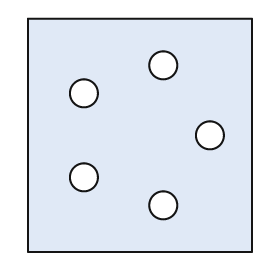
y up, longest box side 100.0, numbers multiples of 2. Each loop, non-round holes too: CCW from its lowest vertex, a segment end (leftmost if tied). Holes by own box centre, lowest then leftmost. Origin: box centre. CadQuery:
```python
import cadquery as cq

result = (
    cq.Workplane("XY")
    .moveTo(-48.0, -50.0)
    .lineTo(48.0, -50.0)
    .lineTo(48.0, 50.0)
    .lineTo(-48.0, 50.0)
    .close()
    .moveTo(10.0, -30.0)
    .circle(6.0)
    .moveTo(-24.0, -18.0)
    .circle(6.0)
    .moveTo(30.0, 0.0)
    .circle(6.0)
    .moveTo(-24.0, 18.0)
    .circle(6.0)
    .moveTo(10.0, 30.0)
    .circle(6.0)
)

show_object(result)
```